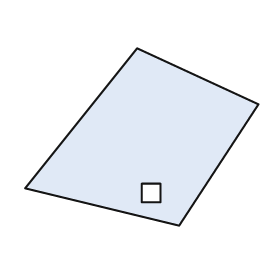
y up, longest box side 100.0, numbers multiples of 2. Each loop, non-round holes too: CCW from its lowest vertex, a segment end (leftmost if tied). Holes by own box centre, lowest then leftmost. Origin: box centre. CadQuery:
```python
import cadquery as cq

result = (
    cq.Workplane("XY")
    .moveTo(16.0, -38.0)
    .lineTo(50.0, 14.0)
    .lineTo(-2.0, 38.0)
    .lineTo(-50.0, -22.0)
    .close()
    .moveTo(0.0, -28.0)
    .lineTo(8.0, -28.0)
    .lineTo(8.0, -20.0)
    .lineTo(0.0, -20.0)
    .close()
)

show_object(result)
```